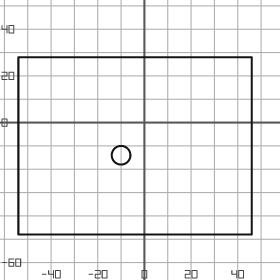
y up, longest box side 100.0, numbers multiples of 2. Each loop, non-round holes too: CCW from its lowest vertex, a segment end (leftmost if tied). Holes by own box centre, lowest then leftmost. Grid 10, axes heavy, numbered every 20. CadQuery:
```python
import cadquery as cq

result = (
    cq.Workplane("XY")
    .moveTo(-54.0, -48.0)
    .lineTo(46.0, -48.0)
    .lineTo(46.0, 28.0)
    .lineTo(-54.0, 28.0)
    .close()
    .moveTo(-10.0, -14.0)
    .circle(4.0)
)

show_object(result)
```